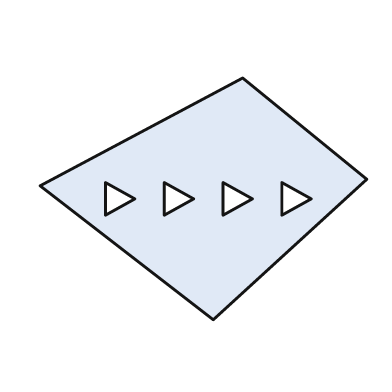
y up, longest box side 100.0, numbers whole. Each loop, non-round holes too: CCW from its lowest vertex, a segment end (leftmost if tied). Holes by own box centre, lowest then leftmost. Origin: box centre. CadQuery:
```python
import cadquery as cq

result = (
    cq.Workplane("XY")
    .moveTo(3.0, -37.0)
    .lineTo(50.0, 6.0)
    .lineTo(12.0, 37.0)
    .lineTo(-50.0, 4.0)
    .close()
    .moveTo(-30.0, -5.0)
    .lineTo(-21.0, 0.0)
    .lineTo(-30.0, 5.0)
    .close()
    .moveTo(-12.0, -5.0)
    .lineTo(-3.0, 0.0)
    .lineTo(-12.0, 5.0)
    .close()
    .moveTo(6.0, -5.0)
    .lineTo(15.0, 0.0)
    .lineTo(6.0, 5.0)
    .close()
    .moveTo(24.0, -5.0)
    .lineTo(33.0, 0.0)
    .lineTo(24.0, 5.0)
    .close()
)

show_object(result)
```